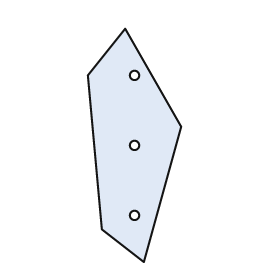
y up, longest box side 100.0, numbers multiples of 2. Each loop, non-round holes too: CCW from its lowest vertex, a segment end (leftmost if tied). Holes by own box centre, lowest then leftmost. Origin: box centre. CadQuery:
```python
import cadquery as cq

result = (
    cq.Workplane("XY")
    .moveTo(4.0, -50.0)
    .lineTo(20.0, 8.0)
    .lineTo(-4.0, 50.0)
    .lineTo(-20.0, 30.0)
    .lineTo(-14.0, -36.0)
    .close()
    .moveTo(0.0, -30.0)
    .circle(2.0)
    .moveTo(0.0, 0.0)
    .circle(2.0)
    .moveTo(0.0, 30.0)
    .circle(2.0)
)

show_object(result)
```